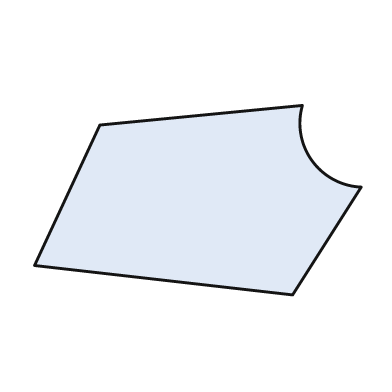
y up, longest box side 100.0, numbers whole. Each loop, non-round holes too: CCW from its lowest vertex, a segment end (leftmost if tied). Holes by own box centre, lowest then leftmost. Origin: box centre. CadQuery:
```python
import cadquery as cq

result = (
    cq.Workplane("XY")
    .moveTo(29.0, -29.0)
    .lineTo(50.0, 4.0)
    .threePointArc((35.0, 12.0), (32.0, 29.0))
    .lineTo(-30.0, 23.0)
    .lineTo(-50.0, -20.0)
    .close()
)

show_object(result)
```